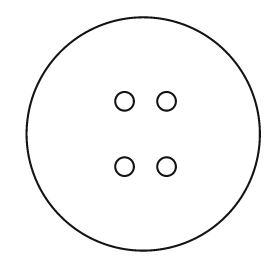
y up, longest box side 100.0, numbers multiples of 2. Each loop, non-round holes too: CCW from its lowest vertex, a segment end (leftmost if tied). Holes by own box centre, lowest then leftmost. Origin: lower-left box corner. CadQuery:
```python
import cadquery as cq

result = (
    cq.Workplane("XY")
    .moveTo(50.0, 50.0)
    .circle(50.0)
    .moveTo(42.0, 36.0)
    .circle(4.0)
    .moveTo(60.0, 36.0)
    .circle(4.0)
    .moveTo(42.0, 64.0)
    .circle(4.0)
    .moveTo(60.0, 64.0)
    .circle(4.0)
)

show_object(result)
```